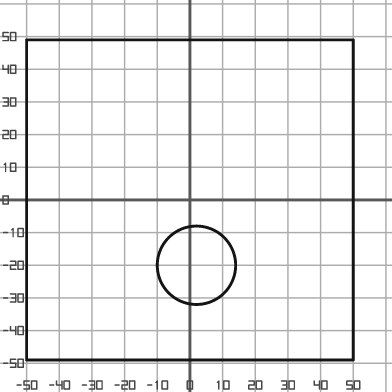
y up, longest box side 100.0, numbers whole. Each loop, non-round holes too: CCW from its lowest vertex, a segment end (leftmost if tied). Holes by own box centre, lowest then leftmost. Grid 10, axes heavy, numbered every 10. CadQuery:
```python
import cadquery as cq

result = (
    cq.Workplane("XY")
    .moveTo(-50.0, -49.0)
    .lineTo(50.0, -49.0)
    .lineTo(50.0, 49.0)
    .lineTo(-50.0, 49.0)
    .close()
    .moveTo(2.0, -20.0)
    .circle(12.0)
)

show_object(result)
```